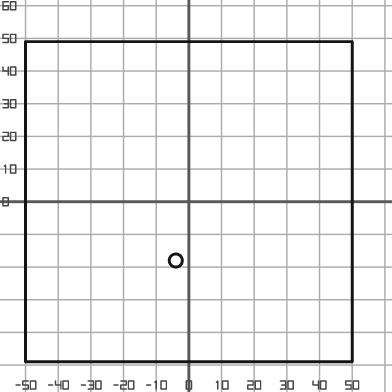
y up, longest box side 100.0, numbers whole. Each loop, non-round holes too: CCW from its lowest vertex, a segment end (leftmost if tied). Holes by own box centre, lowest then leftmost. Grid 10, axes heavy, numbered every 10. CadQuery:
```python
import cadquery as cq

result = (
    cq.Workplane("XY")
    .moveTo(-50.0, -49.0)
    .lineTo(50.0, -49.0)
    .lineTo(50.0, 49.0)
    .lineTo(-50.0, 49.0)
    .close()
    .moveTo(-4.0, -18.0)
    .circle(2.0)
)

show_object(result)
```